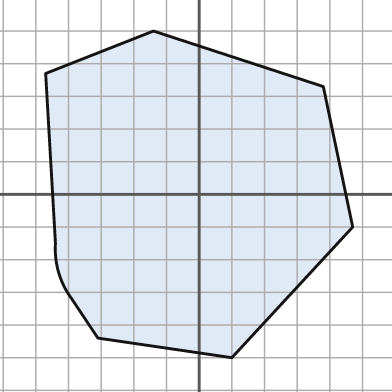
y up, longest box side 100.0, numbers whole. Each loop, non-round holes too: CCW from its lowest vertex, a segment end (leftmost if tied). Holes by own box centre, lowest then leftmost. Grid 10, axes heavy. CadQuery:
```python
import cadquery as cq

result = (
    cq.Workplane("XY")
    .moveTo(10.0, -50.0)
    .lineTo(47.0, -10.0)
    .lineTo(38.0, 33.0)
    .lineTo(-14.0, 50.0)
    .lineTo(-47.0, 37.0)
    .lineTo(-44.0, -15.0)
    .threePointArc((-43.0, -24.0), (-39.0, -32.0))
    .lineTo(-31.0, -44.0)
    .close()
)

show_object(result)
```